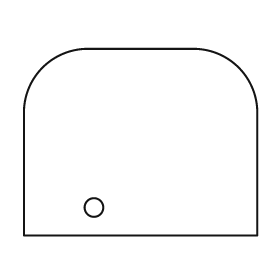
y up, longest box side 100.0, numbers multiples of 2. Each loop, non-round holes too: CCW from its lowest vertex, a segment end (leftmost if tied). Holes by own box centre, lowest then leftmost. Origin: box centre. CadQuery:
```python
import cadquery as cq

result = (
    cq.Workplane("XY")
    .moveTo(-50.0, -40.0)
    .lineTo(50.0, -40.0)
    .lineTo(50.0, 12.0)
    .threePointArc((42.0, 32.0), (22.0, 40.0))
    .lineTo(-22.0, 40.0)
    .threePointArc((-42.0, 32.0), (-50.0, 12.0))
    .close()
    .moveTo(-20.0, -28.0)
    .circle(4.0)
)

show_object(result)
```